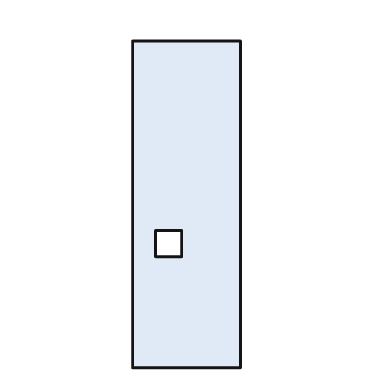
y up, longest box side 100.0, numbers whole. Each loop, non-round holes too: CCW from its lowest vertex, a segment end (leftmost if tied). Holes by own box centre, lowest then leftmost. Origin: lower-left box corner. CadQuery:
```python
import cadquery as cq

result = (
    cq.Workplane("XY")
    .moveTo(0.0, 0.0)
    .lineTo(33.0, 0.0)
    .lineTo(33.0, 100.0)
    .lineTo(0.0, 100.0)
    .close()
    .moveTo(7.0, 34.0)
    .lineTo(15.0, 34.0)
    .lineTo(15.0, 42.0)
    .lineTo(7.0, 42.0)
    .close()
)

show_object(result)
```